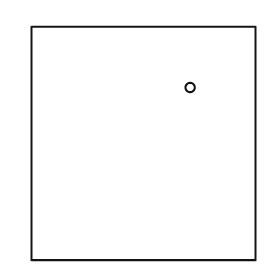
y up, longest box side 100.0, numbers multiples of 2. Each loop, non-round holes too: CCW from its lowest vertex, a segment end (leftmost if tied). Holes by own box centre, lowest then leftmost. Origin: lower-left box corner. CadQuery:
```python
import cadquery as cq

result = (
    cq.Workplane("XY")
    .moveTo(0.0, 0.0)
    .lineTo(96.0, 0.0)
    .lineTo(96.0, 100.0)
    .lineTo(0.0, 100.0)
    .close()
    .moveTo(68.0, 74.0)
    .circle(2.0)
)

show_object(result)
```